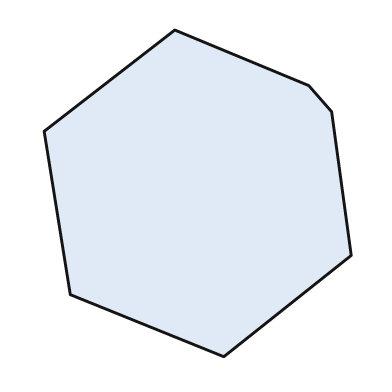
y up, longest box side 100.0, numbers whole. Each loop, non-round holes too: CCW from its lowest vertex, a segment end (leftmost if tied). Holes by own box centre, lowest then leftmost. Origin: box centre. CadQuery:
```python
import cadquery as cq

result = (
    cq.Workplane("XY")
    .moveTo(8.0, -50.0)
    .lineTo(47.0, -19.0)
    .lineTo(41.0, 25.0)
    .lineTo(34.0, 33.0)
    .lineTo(-7.0, 50.0)
    .lineTo(-47.0, 19.0)
    .lineTo(-39.0, -31.0)
    .close()
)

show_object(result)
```